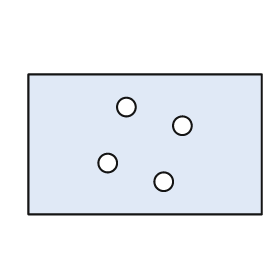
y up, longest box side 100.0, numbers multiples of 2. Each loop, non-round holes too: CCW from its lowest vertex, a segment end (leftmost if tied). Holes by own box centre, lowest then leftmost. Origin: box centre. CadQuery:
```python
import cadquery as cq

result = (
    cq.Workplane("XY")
    .moveTo(-50.0, -30.0)
    .lineTo(50.0, -30.0)
    .lineTo(50.0, 30.0)
    .lineTo(-50.0, 30.0)
    .close()
    .moveTo(8.0, -16.0)
    .circle(4.0)
    .moveTo(-16.0, -8.0)
    .circle(4.0)
    .moveTo(16.0, 8.0)
    .circle(4.0)
    .moveTo(-8.0, 16.0)
    .circle(4.0)
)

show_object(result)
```